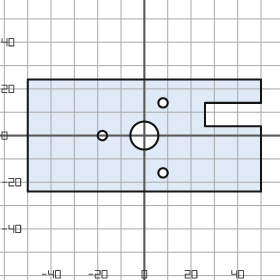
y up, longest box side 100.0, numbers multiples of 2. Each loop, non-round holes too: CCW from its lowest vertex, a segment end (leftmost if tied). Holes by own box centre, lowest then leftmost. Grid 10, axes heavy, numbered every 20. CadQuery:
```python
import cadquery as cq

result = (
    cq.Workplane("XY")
    .moveTo(-50.0, -24.0)
    .lineTo(50.0, -24.0)
    .lineTo(50.0, 4.0)
    .lineTo(26.0, 4.0)
    .lineTo(26.0, 14.0)
    .lineTo(50.0, 14.0)
    .lineTo(50.0, 24.0)
    .lineTo(-50.0, 24.0)
    .close()
    .moveTo(8.0, -16.0)
    .circle(2.0)
    .moveTo(-18.0, 0.0)
    .circle(2.0)
    .moveTo(0.0, 0.0)
    .circle(6.0)
    .moveTo(8.0, 14.0)
    .circle(2.0)
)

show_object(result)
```